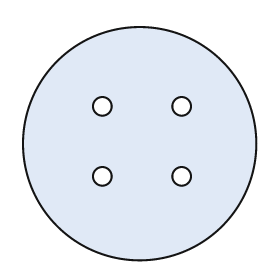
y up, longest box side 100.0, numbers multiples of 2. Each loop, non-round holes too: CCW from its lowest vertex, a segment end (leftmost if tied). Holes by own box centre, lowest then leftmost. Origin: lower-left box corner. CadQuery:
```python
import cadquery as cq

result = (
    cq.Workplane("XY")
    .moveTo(50.0, 50.0)
    .circle(50.0)
    .moveTo(34.0, 36.0)
    .circle(4.0)
    .moveTo(68.0, 36.0)
    .circle(4.0)
    .moveTo(34.0, 66.0)
    .circle(4.0)
    .moveTo(68.0, 66.0)
    .circle(4.0)
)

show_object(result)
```